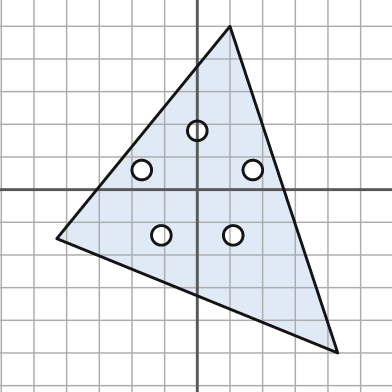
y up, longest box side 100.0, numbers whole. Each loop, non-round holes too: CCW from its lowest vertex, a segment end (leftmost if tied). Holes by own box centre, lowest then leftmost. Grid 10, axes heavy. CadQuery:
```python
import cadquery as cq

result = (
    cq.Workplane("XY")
    .moveTo(43.0, -50.0)
    .lineTo(10.0, 50.0)
    .lineTo(-43.0, -15.0)
    .close()
    .moveTo(-11.0, -14.0)
    .circle(3.0)
    .moveTo(11.0, -14.0)
    .circle(3.0)
    .moveTo(-17.0, 6.0)
    .circle(3.0)
    .moveTo(17.0, 6.0)
    .circle(3.0)
    .moveTo(0.0, 18.0)
    .circle(3.0)
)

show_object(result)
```